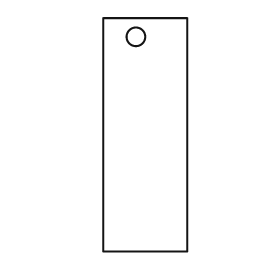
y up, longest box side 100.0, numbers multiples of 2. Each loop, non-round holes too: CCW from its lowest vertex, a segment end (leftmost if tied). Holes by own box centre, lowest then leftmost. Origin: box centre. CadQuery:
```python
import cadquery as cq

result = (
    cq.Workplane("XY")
    .moveTo(-18.0, -50.0)
    .lineTo(18.0, -50.0)
    .lineTo(18.0, 50.0)
    .lineTo(-18.0, 50.0)
    .close()
    .moveTo(-4.0, 42.0)
    .circle(4.0)
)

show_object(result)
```